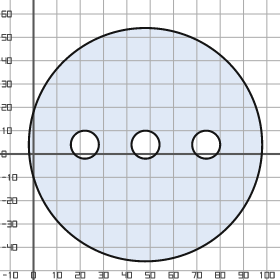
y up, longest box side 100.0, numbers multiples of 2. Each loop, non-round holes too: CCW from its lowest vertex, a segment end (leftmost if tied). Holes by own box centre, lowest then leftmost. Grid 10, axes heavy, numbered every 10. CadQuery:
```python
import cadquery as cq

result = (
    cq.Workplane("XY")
    .moveTo(48.0, 4.0)
    .circle(50.0)
    .moveTo(22.0, 4.0)
    .circle(6.0)
    .moveTo(48.0, 4.0)
    .circle(6.0)
    .moveTo(74.0, 4.0)
    .circle(6.0)
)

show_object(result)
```